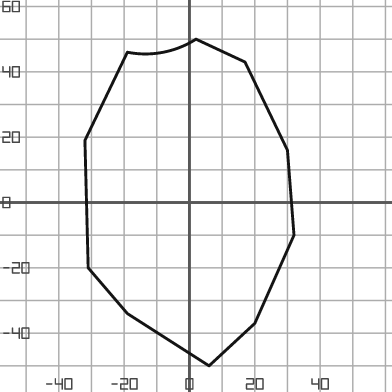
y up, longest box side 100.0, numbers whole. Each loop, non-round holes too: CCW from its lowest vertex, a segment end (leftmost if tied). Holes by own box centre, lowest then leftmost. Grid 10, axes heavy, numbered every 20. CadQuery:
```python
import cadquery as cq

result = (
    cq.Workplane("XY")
    .moveTo(6.0, -50.0)
    .lineTo(20.0, -37.0)
    .lineTo(32.0, -10.0)
    .lineTo(30.0, 16.0)
    .lineTo(17.0, 43.0)
    .lineTo(2.0, 50.0)
    .threePointArc((-8.0, 46.0), (-19.0, 46.0))
    .lineTo(-32.0, 19.0)
    .lineTo(-31.0, -20.0)
    .lineTo(-19.0, -34.0)
    .close()
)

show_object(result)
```